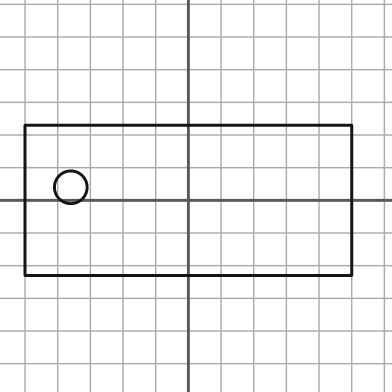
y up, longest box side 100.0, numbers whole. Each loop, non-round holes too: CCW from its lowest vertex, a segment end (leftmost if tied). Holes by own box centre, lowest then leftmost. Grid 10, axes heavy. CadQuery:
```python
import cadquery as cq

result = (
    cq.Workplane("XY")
    .moveTo(-50.0, -23.0)
    .lineTo(50.0, -23.0)
    .lineTo(50.0, 23.0)
    .lineTo(-50.0, 23.0)
    .close()
    .moveTo(-36.0, 4.0)
    .circle(5.0)
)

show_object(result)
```